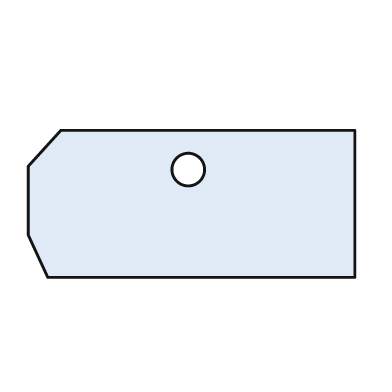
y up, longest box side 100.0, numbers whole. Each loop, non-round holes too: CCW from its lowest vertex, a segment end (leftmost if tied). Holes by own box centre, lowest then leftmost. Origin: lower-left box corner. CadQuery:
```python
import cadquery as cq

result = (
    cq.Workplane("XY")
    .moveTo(6.0, 0.0)
    .lineTo(100.0, 0.0)
    .lineTo(100.0, 45.0)
    .lineTo(10.0, 45.0)
    .lineTo(0.0, 34.0)
    .lineTo(0.0, 13.0)
    .close()
    .moveTo(49.0, 33.0)
    .circle(5.0)
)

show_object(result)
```